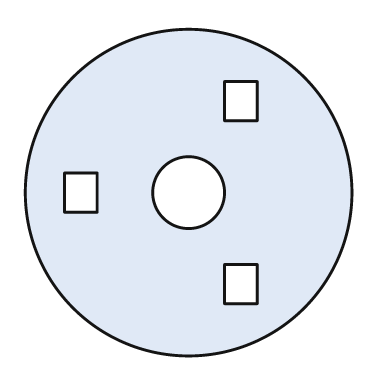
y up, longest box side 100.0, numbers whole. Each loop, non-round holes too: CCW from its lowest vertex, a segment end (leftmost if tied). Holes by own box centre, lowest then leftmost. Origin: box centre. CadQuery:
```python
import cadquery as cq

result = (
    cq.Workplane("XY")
    .moveTo(0.0, 0.0)
    .circle(50.0)
    .moveTo(11.0, -34.0)
    .lineTo(21.0, -34.0)
    .lineTo(21.0, -22.0)
    .lineTo(11.0, -22.0)
    .close()
    .moveTo(-38.0, -6.0)
    .lineTo(-28.0, -6.0)
    .lineTo(-28.0, 6.0)
    .lineTo(-38.0, 6.0)
    .close()
    .moveTo(0.0, 0.0)
    .circle(11.0)
    .moveTo(11.0, 22.0)
    .lineTo(21.0, 22.0)
    .lineTo(21.0, 34.0)
    .lineTo(11.0, 34.0)
    .close()
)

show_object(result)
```